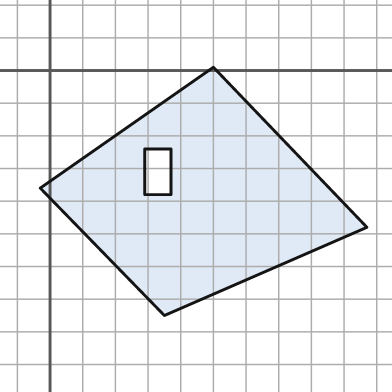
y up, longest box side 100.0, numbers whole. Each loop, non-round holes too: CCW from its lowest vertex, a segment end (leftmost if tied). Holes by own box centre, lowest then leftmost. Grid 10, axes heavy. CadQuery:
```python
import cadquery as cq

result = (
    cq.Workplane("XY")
    .moveTo(35.0, -75.0)
    .lineTo(97.0, -48.0)
    .lineTo(50.0, 1.0)
    .lineTo(-3.0, -36.0)
    .close()
    .moveTo(29.0, -38.0)
    .lineTo(37.0, -38.0)
    .lineTo(37.0, -24.0)
    .lineTo(29.0, -24.0)
    .close()
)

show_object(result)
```